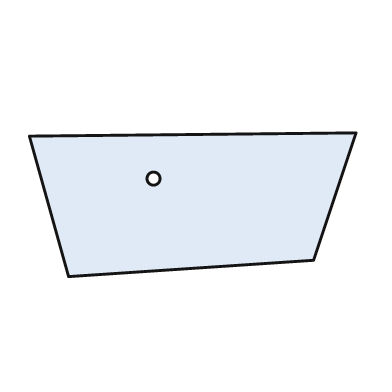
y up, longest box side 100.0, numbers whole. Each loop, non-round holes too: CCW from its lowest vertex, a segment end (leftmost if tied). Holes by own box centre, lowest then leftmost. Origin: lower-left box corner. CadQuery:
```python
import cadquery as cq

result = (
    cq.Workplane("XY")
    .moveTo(12.0, 0.0)
    .lineTo(87.0, 5.0)
    .lineTo(100.0, 44.0)
    .lineTo(0.0, 43.0)
    .close()
    .moveTo(38.0, 30.0)
    .circle(2.0)
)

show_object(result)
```